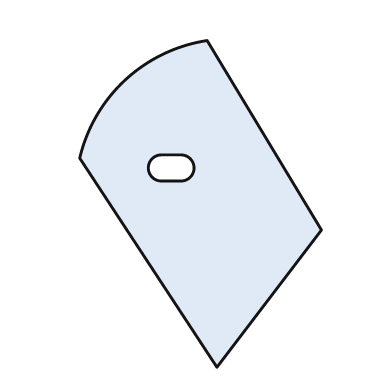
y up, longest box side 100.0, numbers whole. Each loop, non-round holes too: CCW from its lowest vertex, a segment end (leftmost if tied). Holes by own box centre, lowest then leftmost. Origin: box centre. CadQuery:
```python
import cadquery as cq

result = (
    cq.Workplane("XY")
    .moveTo(5.0, -50.0)
    .lineTo(37.0, -8.0)
    .lineTo(2.0, 50.0)
    .threePointArc((-23.0, 38.0), (-37.0, 14.0))
    .close()
    .moveTo(-12.0, 7.0)
    .lineTo(-6.0, 7.0)
    .threePointArc((-2.0, 11.0), (-6.0, 15.0))
    .lineTo(-12.0, 15.0)
    .threePointArc((-16.0, 11.0), (-12.0, 7.0))
    .close()
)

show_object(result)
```